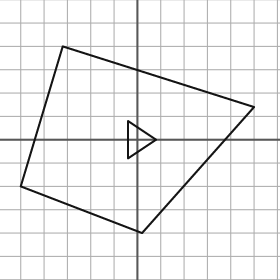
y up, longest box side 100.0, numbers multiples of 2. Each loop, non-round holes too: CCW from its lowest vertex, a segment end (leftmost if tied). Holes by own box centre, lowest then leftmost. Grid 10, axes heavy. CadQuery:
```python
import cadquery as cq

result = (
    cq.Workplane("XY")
    .moveTo(2.0, -40.0)
    .lineTo(50.0, 14.0)
    .lineTo(-32.0, 40.0)
    .lineTo(-50.0, -20.0)
    .close()
    .moveTo(-4.0, -8.0)
    .lineTo(8.0, 0.0)
    .lineTo(-4.0, 8.0)
    .close()
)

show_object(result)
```